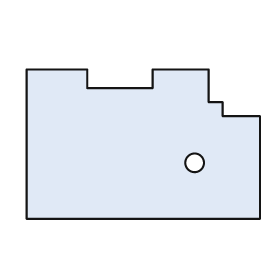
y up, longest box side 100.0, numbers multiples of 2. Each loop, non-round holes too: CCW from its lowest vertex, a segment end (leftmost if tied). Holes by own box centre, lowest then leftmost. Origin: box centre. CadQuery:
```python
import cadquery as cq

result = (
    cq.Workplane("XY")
    .moveTo(-50.0, -32.0)
    .lineTo(50.0, -32.0)
    .lineTo(50.0, 12.0)
    .lineTo(34.0, 12.0)
    .lineTo(34.0, 18.0)
    .lineTo(28.0, 18.0)
    .lineTo(28.0, 32.0)
    .lineTo(4.0, 32.0)
    .lineTo(4.0, 24.0)
    .lineTo(-24.0, 24.0)
    .lineTo(-24.0, 32.0)
    .lineTo(-50.0, 32.0)
    .close()
    .moveTo(22.0, -8.0)
    .circle(4.0)
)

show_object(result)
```